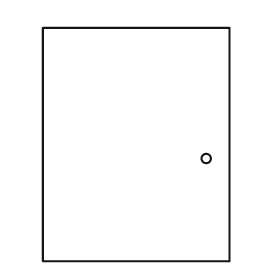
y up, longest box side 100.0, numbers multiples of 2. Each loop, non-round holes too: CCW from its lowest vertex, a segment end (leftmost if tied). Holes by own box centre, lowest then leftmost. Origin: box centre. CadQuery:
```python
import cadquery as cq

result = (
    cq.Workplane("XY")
    .moveTo(-40.0, -50.0)
    .lineTo(40.0, -50.0)
    .lineTo(40.0, 50.0)
    .lineTo(-40.0, 50.0)
    .close()
    .moveTo(30.0, -6.0)
    .circle(2.0)
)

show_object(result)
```